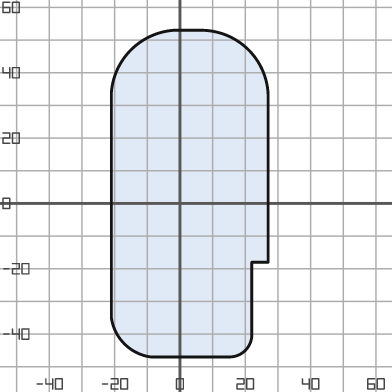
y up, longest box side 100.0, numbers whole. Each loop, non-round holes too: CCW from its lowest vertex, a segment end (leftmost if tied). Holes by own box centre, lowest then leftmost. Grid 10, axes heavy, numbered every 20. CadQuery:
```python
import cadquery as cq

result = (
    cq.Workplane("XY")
    .moveTo(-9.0, -47.0)
    .lineTo(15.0, -47.0)
    .threePointArc((20.0, -45.0), (22.0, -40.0))
    .lineTo(22.0, -18.0)
    .lineTo(27.0, -18.0)
    .lineTo(27.0, 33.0)
    .threePointArc((21.0, 47.0), (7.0, 53.0))
    .lineTo(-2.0, 53.0)
    .threePointArc((-15.0, 47.0), (-21.0, 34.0))
    .lineTo(-21.0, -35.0)
    .threePointArc((-17.0, -43.0), (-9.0, -47.0))
    .close()
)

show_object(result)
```